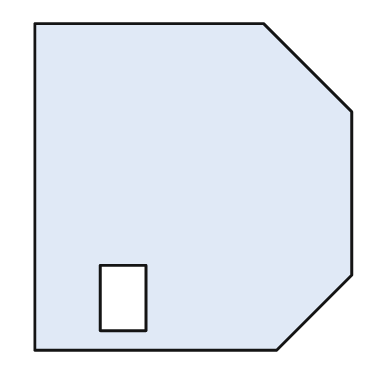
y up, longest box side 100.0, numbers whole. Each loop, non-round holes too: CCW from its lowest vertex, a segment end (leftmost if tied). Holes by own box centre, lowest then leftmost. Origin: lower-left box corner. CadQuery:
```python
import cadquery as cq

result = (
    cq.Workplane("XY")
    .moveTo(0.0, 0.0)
    .lineTo(74.0, 0.0)
    .lineTo(97.0, 23.0)
    .lineTo(97.0, 73.0)
    .lineTo(70.0, 100.0)
    .lineTo(0.0, 100.0)
    .close()
    .moveTo(20.0, 6.0)
    .lineTo(34.0, 6.0)
    .lineTo(34.0, 26.0)
    .lineTo(20.0, 26.0)
    .close()
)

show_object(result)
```